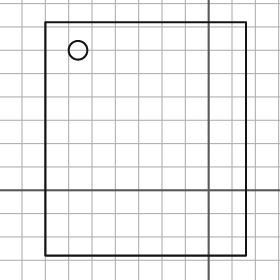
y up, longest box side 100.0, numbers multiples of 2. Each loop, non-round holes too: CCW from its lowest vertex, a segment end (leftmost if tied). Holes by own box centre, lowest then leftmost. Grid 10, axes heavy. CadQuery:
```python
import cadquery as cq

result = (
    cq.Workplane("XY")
    .moveTo(-70.0, -28.0)
    .lineTo(16.0, -28.0)
    .lineTo(16.0, 72.0)
    .lineTo(-70.0, 72.0)
    .close()
    .moveTo(-56.0, 60.0)
    .circle(4.0)
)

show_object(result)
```